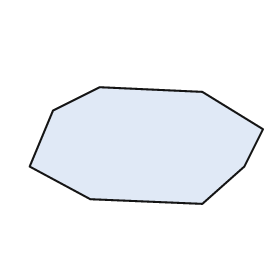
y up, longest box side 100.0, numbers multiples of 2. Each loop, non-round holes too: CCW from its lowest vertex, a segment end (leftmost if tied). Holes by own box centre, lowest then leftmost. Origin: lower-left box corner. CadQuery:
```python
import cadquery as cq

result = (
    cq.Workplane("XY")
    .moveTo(74.0, 0.0)
    .lineTo(92.0, 16.0)
    .lineTo(100.0, 32.0)
    .lineTo(74.0, 48.0)
    .lineTo(30.0, 50.0)
    .lineTo(10.0, 40.0)
    .lineTo(0.0, 16.0)
    .lineTo(26.0, 2.0)
    .close()
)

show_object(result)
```